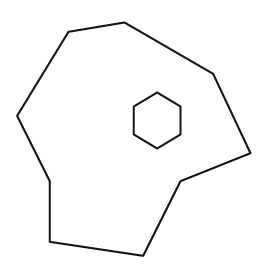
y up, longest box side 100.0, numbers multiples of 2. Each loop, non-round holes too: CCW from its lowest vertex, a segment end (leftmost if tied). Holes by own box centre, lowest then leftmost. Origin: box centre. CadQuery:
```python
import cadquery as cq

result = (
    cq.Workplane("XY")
    .moveTo(4.0, -50.0)
    .lineTo(20.0, -18.0)
    .lineTo(50.0, -6.0)
    .lineTo(34.0, 28.0)
    .lineTo(-4.0, 50.0)
    .lineTo(-28.0, 46.0)
    .lineTo(-50.0, 10.0)
    .lineTo(-36.0, -18.0)
    .lineTo(-36.0, -44.0)
    .close()
    .moveTo(10.0, -4.0)
    .lineTo(20.0, 2.0)
    .lineTo(20.0, 14.0)
    .lineTo(10.0, 20.0)
    .lineTo(0.0, 14.0)
    .lineTo(0.0, 2.0)
    .close()
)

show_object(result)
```